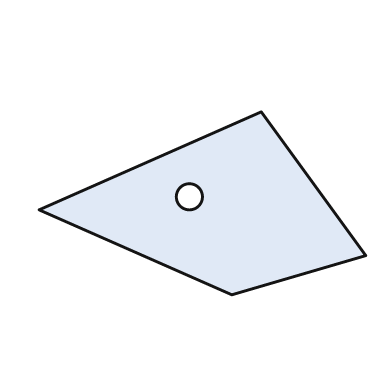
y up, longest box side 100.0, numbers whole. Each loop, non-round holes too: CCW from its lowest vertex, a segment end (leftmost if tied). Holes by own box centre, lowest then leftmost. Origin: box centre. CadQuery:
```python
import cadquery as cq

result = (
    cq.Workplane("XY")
    .moveTo(9.0, -28.0)
    .lineTo(50.0, -16.0)
    .lineTo(18.0, 28.0)
    .lineTo(-50.0, -2.0)
    .close()
    .moveTo(-4.0, 2.0)
    .circle(4.0)
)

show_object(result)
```